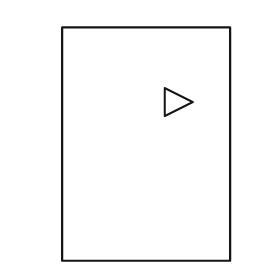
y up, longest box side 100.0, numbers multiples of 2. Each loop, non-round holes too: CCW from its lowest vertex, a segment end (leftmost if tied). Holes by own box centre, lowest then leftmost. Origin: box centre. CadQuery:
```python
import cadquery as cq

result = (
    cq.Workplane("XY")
    .moveTo(-36.0, -50.0)
    .lineTo(36.0, -50.0)
    .lineTo(36.0, 50.0)
    .lineTo(-36.0, 50.0)
    .close()
    .moveTo(8.0, 12.0)
    .lineTo(20.0, 18.0)
    .lineTo(8.0, 24.0)
    .close()
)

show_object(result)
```